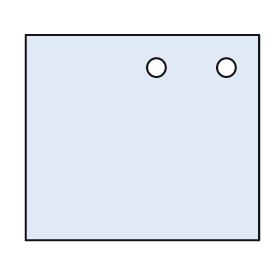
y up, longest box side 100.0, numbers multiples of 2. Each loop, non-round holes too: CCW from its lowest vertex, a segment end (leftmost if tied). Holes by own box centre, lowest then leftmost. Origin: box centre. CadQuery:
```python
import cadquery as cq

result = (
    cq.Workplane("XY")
    .moveTo(-50.0, -44.0)
    .lineTo(50.0, -44.0)
    .lineTo(50.0, 44.0)
    .lineTo(-50.0, 44.0)
    .close()
    .moveTo(6.0, 30.0)
    .circle(4.0)
    .moveTo(36.0, 30.0)
    .circle(4.0)
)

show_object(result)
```